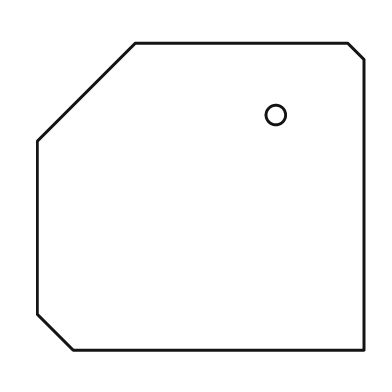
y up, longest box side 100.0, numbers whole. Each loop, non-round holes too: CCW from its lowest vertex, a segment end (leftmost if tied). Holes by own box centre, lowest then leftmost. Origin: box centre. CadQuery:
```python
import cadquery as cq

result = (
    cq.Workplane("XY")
    .moveTo(-39.0, -47.0)
    .lineTo(50.0, -47.0)
    .lineTo(50.0, 42.0)
    .lineTo(45.0, 47.0)
    .lineTo(-20.0, 47.0)
    .lineTo(-50.0, 17.0)
    .lineTo(-50.0, -36.0)
    .close()
    .moveTo(23.0, 25.0)
    .circle(3.0)
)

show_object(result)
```